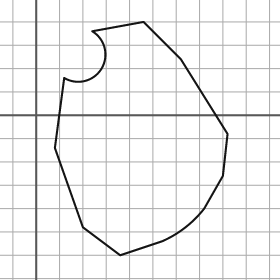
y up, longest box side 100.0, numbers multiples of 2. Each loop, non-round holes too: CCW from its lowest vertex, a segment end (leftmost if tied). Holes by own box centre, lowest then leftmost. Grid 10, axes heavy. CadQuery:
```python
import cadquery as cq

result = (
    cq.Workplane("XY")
    .moveTo(36.0, -60.0)
    .lineTo(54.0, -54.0)
    .threePointArc((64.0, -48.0), (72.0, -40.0))
    .lineTo(80.0, -26.0)
    .lineTo(82.0, -8.0)
    .lineTo(62.0, 24.0)
    .lineTo(46.0, 40.0)
    .lineTo(24.0, 36.0)
    .threePointArc((28.0, 20.0), (12.0, 16.0))
    .lineTo(8.0, -14.0)
    .lineTo(20.0, -48.0)
    .close()
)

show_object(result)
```